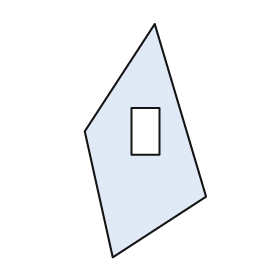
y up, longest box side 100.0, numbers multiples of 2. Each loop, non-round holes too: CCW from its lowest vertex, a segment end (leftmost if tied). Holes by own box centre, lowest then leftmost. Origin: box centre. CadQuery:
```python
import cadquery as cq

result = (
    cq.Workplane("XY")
    .moveTo(-14.0, -50.0)
    .lineTo(26.0, -24.0)
    .lineTo(4.0, 50.0)
    .lineTo(-26.0, 4.0)
    .close()
    .moveTo(-6.0, -6.0)
    .lineTo(6.0, -6.0)
    .lineTo(6.0, 14.0)
    .lineTo(-6.0, 14.0)
    .close()
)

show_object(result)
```